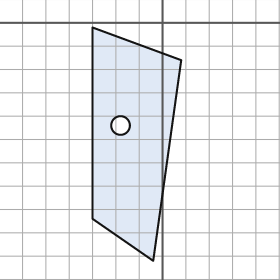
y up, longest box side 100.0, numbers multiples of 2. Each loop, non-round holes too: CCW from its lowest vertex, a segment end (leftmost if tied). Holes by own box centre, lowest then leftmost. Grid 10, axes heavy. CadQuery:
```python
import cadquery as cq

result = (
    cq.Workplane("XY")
    .moveTo(-4.0, -102.0)
    .lineTo(8.0, -16.0)
    .lineTo(-30.0, -2.0)
    .lineTo(-30.0, -84.0)
    .close()
    .moveTo(-18.0, -44.0)
    .circle(4.0)
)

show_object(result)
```